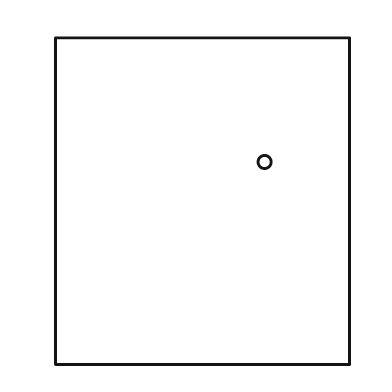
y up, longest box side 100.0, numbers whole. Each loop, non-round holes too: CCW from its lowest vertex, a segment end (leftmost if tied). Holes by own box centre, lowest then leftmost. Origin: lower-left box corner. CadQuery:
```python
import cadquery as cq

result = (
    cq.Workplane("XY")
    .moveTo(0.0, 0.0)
    .lineTo(90.0, 0.0)
    .lineTo(90.0, 100.0)
    .lineTo(0.0, 100.0)
    .close()
    .moveTo(64.0, 62.0)
    .circle(2.0)
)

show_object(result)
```